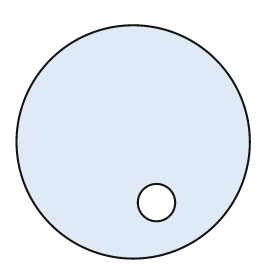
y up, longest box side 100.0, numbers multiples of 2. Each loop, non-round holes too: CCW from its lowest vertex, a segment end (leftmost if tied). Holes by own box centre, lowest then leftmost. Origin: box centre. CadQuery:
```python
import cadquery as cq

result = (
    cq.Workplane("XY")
    .moveTo(0.0, 0.0)
    .circle(50.0)
    .moveTo(10.0, -26.0)
    .circle(8.0)
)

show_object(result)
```